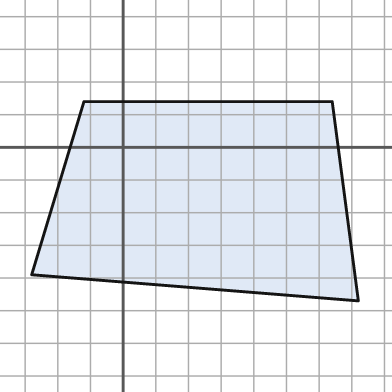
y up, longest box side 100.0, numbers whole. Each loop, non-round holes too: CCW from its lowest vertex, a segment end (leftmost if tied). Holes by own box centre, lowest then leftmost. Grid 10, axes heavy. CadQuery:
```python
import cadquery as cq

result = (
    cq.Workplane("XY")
    .moveTo(72.0, -47.0)
    .lineTo(64.0, 14.0)
    .lineTo(-12.0, 14.0)
    .lineTo(-28.0, -39.0)
    .close()
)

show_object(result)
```